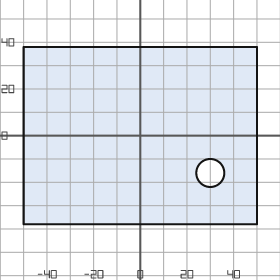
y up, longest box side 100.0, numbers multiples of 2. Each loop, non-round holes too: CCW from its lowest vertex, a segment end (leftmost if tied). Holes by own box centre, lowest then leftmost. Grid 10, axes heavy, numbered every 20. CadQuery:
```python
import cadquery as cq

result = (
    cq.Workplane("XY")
    .moveTo(-50.0, -38.0)
    .lineTo(50.0, -38.0)
    .lineTo(50.0, 38.0)
    .lineTo(-50.0, 38.0)
    .close()
    .moveTo(30.0, -16.0)
    .circle(6.0)
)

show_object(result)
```